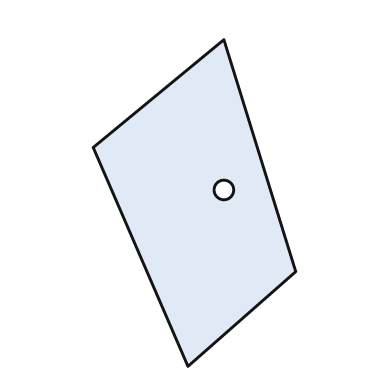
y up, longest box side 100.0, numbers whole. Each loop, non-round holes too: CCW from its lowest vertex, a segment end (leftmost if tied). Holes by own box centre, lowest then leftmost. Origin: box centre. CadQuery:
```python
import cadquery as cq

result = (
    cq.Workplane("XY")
    .moveTo(-2.0, -50.0)
    .lineTo(31.0, -21.0)
    .lineTo(9.0, 50.0)
    .lineTo(-31.0, 17.0)
    .close()
    .moveTo(9.0, 4.0)
    .circle(3.0)
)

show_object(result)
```